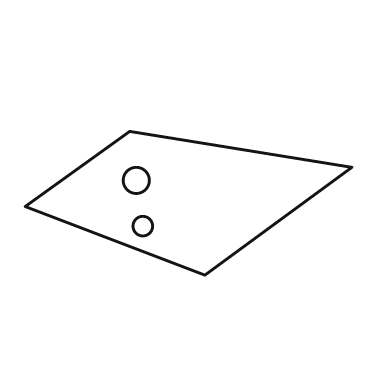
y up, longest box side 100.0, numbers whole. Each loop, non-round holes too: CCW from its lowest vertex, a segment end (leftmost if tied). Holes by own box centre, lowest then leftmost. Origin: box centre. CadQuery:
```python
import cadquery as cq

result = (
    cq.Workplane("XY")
    .moveTo(5.0, -22.0)
    .lineTo(50.0, 11.0)
    .lineTo(-18.0, 22.0)
    .lineTo(-50.0, -1.0)
    .close()
    .moveTo(-14.0, -7.0)
    .circle(3.0)
    .moveTo(-16.0, 7.0)
    .circle(4.0)
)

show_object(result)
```